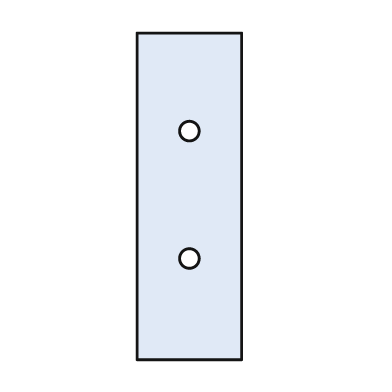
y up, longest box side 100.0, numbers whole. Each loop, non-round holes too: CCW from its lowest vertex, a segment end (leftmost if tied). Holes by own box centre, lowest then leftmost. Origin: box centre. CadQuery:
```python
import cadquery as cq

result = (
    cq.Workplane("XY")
    .moveTo(-16.0, -50.0)
    .lineTo(16.0, -50.0)
    .lineTo(16.0, 50.0)
    .lineTo(-16.0, 50.0)
    .close()
    .moveTo(0.0, -19.0)
    .circle(3.0)
    .moveTo(0.0, 20.0)
    .circle(3.0)
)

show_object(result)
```